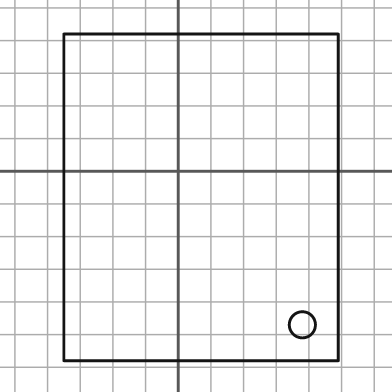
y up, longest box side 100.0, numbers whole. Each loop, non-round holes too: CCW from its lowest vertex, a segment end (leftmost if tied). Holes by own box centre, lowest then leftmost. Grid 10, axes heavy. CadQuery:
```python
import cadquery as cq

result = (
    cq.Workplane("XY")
    .moveTo(-35.0, -58.0)
    .lineTo(49.0, -58.0)
    .lineTo(49.0, 42.0)
    .lineTo(-35.0, 42.0)
    .close()
    .moveTo(38.0, -47.0)
    .circle(4.0)
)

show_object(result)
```